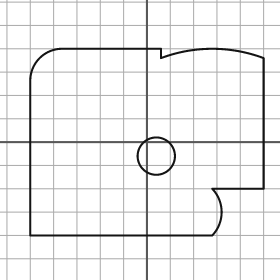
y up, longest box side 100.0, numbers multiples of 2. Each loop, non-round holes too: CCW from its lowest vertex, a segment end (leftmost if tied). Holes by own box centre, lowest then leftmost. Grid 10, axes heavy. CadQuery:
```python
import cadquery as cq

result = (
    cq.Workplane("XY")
    .moveTo(-50.0, -40.0)
    .lineTo(28.0, -40.0)
    .threePointArc((32.0, -30.0), (28.0, -20.0))
    .lineTo(50.0, -20.0)
    .lineTo(50.0, 36.0)
    .threePointArc((28.0, 40.0), (6.0, 36.0))
    .lineTo(6.0, 40.0)
    .lineTo(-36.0, 40.0)
    .threePointArc((-46.0, 36.0), (-50.0, 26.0))
    .close()
    .moveTo(4.0, -6.0)
    .circle(8.0)
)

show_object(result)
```